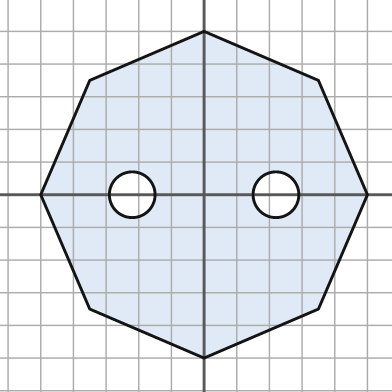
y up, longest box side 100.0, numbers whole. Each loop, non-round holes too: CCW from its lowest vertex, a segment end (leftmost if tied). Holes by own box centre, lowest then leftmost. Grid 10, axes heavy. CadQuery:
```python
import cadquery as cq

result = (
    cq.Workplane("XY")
    .moveTo(0.0, -50.0)
    .lineTo(35.0, -35.0)
    .lineTo(50.0, 0.0)
    .lineTo(35.0, 35.0)
    .lineTo(0.0, 50.0)
    .lineTo(-35.0, 35.0)
    .lineTo(-50.0, 0.0)
    .lineTo(-35.0, -35.0)
    .close()
    .moveTo(-22.0, 0.0)
    .circle(7.0)
    .moveTo(22.0, 0.0)
    .circle(7.0)
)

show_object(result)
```